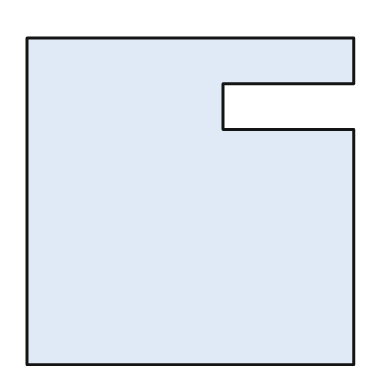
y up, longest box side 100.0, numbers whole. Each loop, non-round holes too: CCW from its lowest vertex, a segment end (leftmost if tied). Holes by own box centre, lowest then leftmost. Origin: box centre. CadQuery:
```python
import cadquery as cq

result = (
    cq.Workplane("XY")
    .moveTo(-50.0, -50.0)
    .lineTo(50.0, -50.0)
    .lineTo(50.0, 22.0)
    .lineTo(10.0, 22.0)
    .lineTo(10.0, 36.0)
    .lineTo(50.0, 36.0)
    .lineTo(50.0, 50.0)
    .lineTo(-50.0, 50.0)
    .close()
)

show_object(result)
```